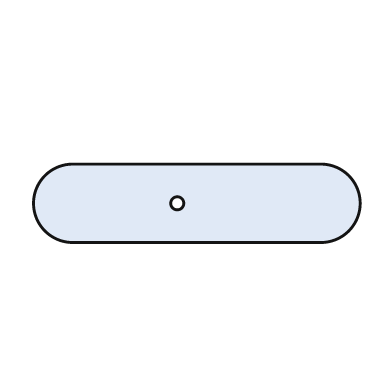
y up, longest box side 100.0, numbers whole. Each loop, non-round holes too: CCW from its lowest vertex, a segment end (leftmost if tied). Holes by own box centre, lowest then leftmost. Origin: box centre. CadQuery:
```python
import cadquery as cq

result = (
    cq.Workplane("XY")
    .moveTo(-38.0, -12.0)
    .lineTo(38.0, -12.0)
    .threePointArc((50.0, 0.0), (38.0, 12.0))
    .lineTo(-38.0, 12.0)
    .threePointArc((-50.0, 0.0), (-38.0, -12.0))
    .close()
    .moveTo(-6.0, 0.0)
    .circle(2.0)
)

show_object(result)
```